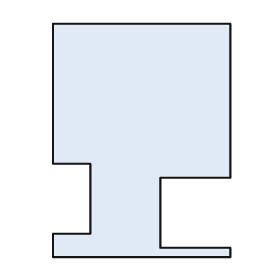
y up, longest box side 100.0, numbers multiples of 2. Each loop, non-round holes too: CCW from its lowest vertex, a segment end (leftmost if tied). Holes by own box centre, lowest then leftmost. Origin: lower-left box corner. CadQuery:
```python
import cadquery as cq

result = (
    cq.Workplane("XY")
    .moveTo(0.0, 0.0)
    .lineTo(76.0, 0.0)
    .lineTo(76.0, 4.0)
    .lineTo(46.0, 4.0)
    .lineTo(46.0, 34.0)
    .lineTo(76.0, 34.0)
    .lineTo(76.0, 100.0)
    .lineTo(0.0, 100.0)
    .lineTo(0.0, 40.0)
    .lineTo(16.0, 40.0)
    .lineTo(16.0, 10.0)
    .lineTo(0.0, 10.0)
    .close()
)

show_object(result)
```